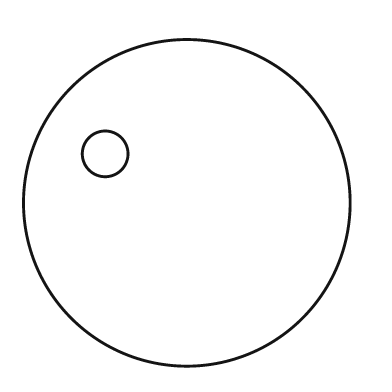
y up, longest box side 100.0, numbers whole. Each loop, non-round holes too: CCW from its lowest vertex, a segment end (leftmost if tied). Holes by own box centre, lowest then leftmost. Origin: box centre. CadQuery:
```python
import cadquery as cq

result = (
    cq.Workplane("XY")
    .moveTo(0.0, 0.0)
    .circle(50.0)
    .moveTo(-25.0, 15.0)
    .circle(7.0)
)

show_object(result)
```